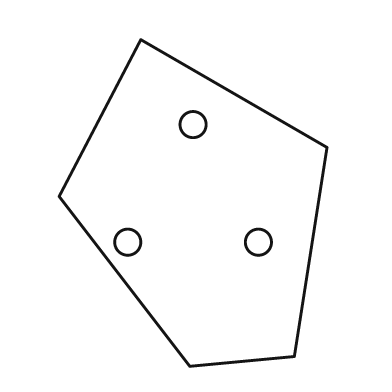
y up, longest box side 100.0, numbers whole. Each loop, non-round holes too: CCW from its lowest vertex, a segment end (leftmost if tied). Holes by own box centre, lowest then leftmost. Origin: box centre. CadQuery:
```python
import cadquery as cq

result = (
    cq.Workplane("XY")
    .moveTo(-1.0, -50.0)
    .lineTo(31.0, -47.0)
    .lineTo(41.0, 17.0)
    .lineTo(-16.0, 50.0)
    .lineTo(-41.0, 2.0)
    .close()
    .moveTo(-20.0, -12.0)
    .circle(4.0)
    .moveTo(20.0, -12.0)
    .circle(4.0)
    .moveTo(0.0, 24.0)
    .circle(4.0)
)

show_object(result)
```